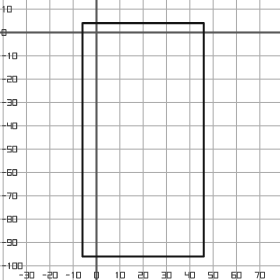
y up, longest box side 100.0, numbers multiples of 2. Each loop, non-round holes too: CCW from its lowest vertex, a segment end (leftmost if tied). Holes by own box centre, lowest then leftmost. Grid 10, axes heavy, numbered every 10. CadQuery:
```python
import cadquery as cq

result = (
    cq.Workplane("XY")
    .moveTo(-6.0, -96.0)
    .lineTo(46.0, -96.0)
    .lineTo(46.0, 4.0)
    .lineTo(-6.0, 4.0)
    .close()
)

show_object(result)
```